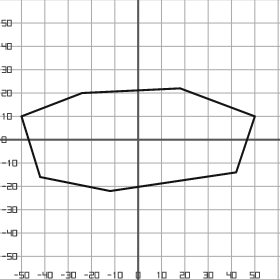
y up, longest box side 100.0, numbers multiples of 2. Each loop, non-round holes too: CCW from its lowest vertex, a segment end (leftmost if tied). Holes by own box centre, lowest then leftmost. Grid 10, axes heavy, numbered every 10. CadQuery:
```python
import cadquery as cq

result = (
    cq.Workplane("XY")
    .moveTo(-12.0, -22.0)
    .lineTo(42.0, -14.0)
    .lineTo(50.0, 10.0)
    .lineTo(18.0, 22.0)
    .lineTo(-24.0, 20.0)
    .lineTo(-50.0, 10.0)
    .lineTo(-42.0, -16.0)
    .close()
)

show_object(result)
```